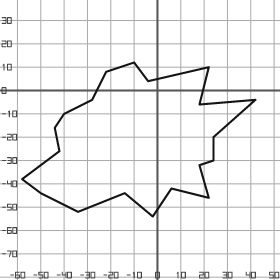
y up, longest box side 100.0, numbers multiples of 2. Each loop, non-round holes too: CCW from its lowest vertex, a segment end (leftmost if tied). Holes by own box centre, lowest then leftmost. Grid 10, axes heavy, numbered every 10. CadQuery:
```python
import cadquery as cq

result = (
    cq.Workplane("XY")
    .moveTo(-2.0, -54.0)
    .lineTo(6.0, -42.0)
    .lineTo(22.0, -46.0)
    .lineTo(18.0, -32.0)
    .lineTo(24.0, -30.0)
    .lineTo(24.0, -20.0)
    .lineTo(42.0, -4.0)
    .lineTo(18.0, -6.0)
    .lineTo(22.0, 10.0)
    .lineTo(-4.0, 4.0)
    .lineTo(-10.0, 12.0)
    .lineTo(-22.0, 8.0)
    .lineTo(-28.0, -4.0)
    .lineTo(-40.0, -10.0)
    .lineTo(-44.0, -16.0)
    .lineTo(-42.0, -26.0)
    .lineTo(-58.0, -38.0)
    .lineTo(-50.0, -44.0)
    .lineTo(-34.0, -52.0)
    .lineTo(-14.0, -44.0)
    .close()
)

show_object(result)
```